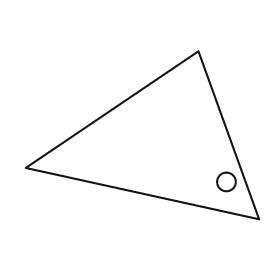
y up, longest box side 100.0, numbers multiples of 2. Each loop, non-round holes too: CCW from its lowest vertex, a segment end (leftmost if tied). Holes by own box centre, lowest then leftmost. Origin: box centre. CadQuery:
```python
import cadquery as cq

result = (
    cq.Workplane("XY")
    .moveTo(50.0, -36.0)
    .lineTo(24.0, 36.0)
    .lineTo(-50.0, -14.0)
    .close()
    .moveTo(36.0, -20.0)
    .circle(4.0)
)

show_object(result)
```